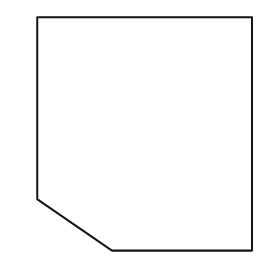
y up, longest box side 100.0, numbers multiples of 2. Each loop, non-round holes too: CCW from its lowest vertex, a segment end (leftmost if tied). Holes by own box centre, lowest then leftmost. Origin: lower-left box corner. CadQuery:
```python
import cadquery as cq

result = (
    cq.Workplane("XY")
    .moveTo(32.0, 0.0)
    .lineTo(92.0, 0.0)
    .lineTo(92.0, 100.0)
    .lineTo(0.0, 100.0)
    .lineTo(0.0, 22.0)
    .close()
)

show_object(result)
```